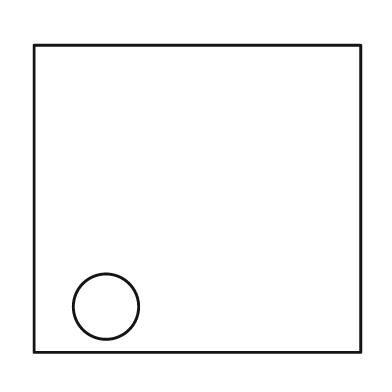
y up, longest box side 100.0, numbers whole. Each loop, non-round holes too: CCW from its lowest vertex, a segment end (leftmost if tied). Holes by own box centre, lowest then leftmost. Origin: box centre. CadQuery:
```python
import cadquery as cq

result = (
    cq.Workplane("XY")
    .moveTo(-50.0, -47.0)
    .lineTo(50.0, -47.0)
    .lineTo(50.0, 47.0)
    .lineTo(-50.0, 47.0)
    .close()
    .moveTo(-28.0, -33.0)
    .circle(10.0)
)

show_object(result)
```